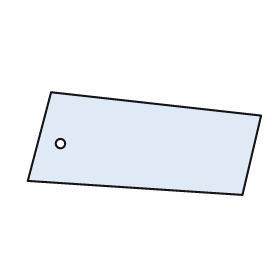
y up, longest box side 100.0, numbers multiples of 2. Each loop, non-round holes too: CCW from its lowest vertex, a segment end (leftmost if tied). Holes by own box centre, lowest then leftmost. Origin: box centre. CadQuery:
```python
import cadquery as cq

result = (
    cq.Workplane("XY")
    .moveTo(42.0, -22.0)
    .lineTo(50.0, 12.0)
    .lineTo(-40.0, 22.0)
    .lineTo(-50.0, -16.0)
    .close()
    .moveTo(-36.0, 0.0)
    .circle(2.0)
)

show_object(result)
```